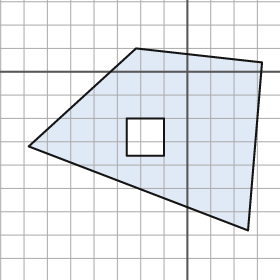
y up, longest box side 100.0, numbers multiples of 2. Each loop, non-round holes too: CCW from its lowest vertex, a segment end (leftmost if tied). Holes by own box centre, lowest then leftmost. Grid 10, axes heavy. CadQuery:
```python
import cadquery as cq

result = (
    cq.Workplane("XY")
    .moveTo(26.0, -68.0)
    .lineTo(32.0, 4.0)
    .lineTo(-22.0, 10.0)
    .lineTo(-68.0, -32.0)
    .close()
    .moveTo(-26.0, -36.0)
    .lineTo(-10.0, -36.0)
    .lineTo(-10.0, -20.0)
    .lineTo(-26.0, -20.0)
    .close()
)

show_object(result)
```